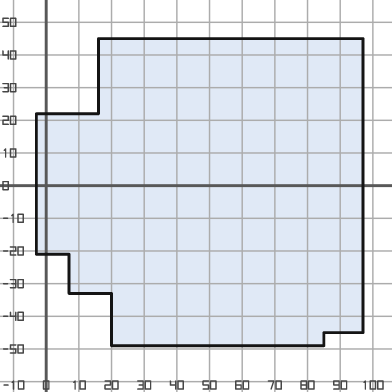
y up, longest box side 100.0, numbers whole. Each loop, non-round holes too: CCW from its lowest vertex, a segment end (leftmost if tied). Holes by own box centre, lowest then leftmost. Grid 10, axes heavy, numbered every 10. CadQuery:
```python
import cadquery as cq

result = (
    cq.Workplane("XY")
    .moveTo(20.0, -49.0)
    .lineTo(85.0, -49.0)
    .lineTo(85.0, -45.0)
    .lineTo(97.0, -45.0)
    .lineTo(97.0, 45.0)
    .lineTo(16.0, 45.0)
    .lineTo(16.0, 22.0)
    .lineTo(-3.0, 22.0)
    .lineTo(-3.0, -21.0)
    .lineTo(7.0, -21.0)
    .lineTo(7.0, -33.0)
    .lineTo(20.0, -33.0)
    .close()
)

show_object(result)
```